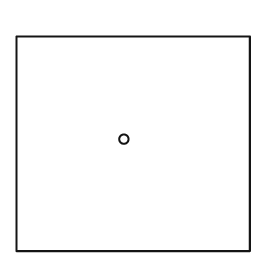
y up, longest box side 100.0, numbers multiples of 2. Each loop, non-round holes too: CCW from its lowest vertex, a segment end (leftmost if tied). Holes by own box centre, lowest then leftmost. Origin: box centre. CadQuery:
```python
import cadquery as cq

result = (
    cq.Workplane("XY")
    .moveTo(-50.0, -46.0)
    .lineTo(50.0, -46.0)
    .lineTo(50.0, 46.0)
    .lineTo(-50.0, 46.0)
    .close()
    .moveTo(-4.0, 2.0)
    .circle(2.0)
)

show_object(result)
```